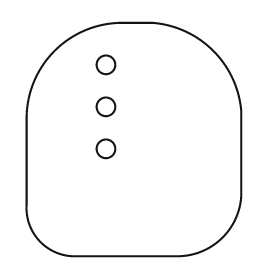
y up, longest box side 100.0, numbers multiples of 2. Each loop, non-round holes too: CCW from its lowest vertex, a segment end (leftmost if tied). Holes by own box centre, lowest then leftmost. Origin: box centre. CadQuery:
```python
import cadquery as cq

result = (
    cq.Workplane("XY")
    .moveTo(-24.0, -50.0)
    .lineTo(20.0, -50.0)
    .threePointArc((38.0, -42.0), (46.0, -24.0))
    .lineTo(46.0, 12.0)
    .threePointArc((34.0, 38.0), (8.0, 50.0))
    .lineTo(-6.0, 50.0)
    .threePointArc((-34.0, 38.0), (-46.0, 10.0))
    .lineTo(-46.0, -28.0)
    .threePointArc((-40.0, -44.0), (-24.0, -50.0))
    .close()
    .moveTo(-12.0, -4.0)
    .circle(4.0)
    .moveTo(-12.0, 14.0)
    .circle(4.0)
    .moveTo(-12.0, 32.0)
    .circle(4.0)
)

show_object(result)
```